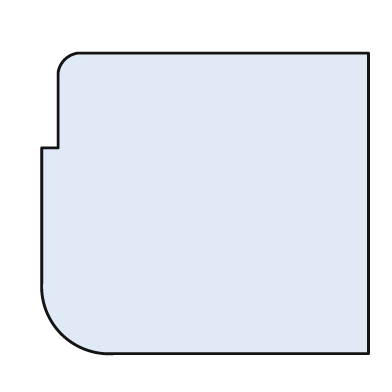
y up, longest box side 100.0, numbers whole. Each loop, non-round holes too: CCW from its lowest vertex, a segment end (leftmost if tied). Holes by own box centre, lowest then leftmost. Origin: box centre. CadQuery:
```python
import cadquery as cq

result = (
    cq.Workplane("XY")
    .moveTo(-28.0, -46.0)
    .lineTo(50.0, -46.0)
    .lineTo(50.0, 46.0)
    .lineTo(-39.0, 46.0)
    .threePointArc((-43.0, 44.0), (-45.0, 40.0))
    .lineTo(-45.0, 17.0)
    .lineTo(-50.0, 17.0)
    .lineTo(-50.0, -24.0)
    .threePointArc((-44.0, -40.0), (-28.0, -46.0))
    .close()
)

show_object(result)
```